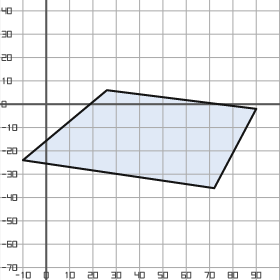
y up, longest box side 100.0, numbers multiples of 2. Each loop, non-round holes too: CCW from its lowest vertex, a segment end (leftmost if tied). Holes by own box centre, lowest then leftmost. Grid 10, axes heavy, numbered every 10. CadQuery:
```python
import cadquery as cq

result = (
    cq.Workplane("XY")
    .moveTo(72.0, -36.0)
    .lineTo(90.0, -2.0)
    .lineTo(26.0, 6.0)
    .lineTo(-10.0, -24.0)
    .close()
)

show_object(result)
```